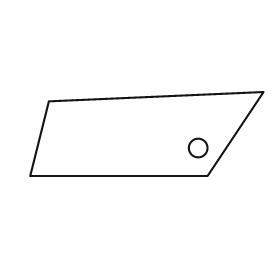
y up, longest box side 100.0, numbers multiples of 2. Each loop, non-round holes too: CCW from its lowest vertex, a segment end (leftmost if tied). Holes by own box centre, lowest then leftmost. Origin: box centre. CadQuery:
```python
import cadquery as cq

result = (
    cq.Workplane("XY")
    .moveTo(-50.0, -18.0)
    .lineTo(26.0, -18.0)
    .lineTo(50.0, 18.0)
    .lineTo(-42.0, 14.0)
    .close()
    .moveTo(22.0, -6.0)
    .circle(4.0)
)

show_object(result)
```